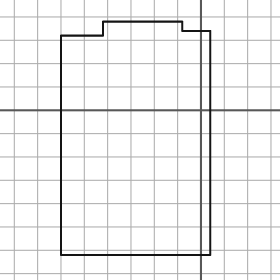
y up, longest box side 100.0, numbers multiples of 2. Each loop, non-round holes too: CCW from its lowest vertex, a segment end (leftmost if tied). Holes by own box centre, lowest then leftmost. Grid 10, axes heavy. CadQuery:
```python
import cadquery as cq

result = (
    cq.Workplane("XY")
    .moveTo(-60.0, -62.0)
    .lineTo(4.0, -62.0)
    .lineTo(4.0, 34.0)
    .lineTo(-8.0, 34.0)
    .lineTo(-8.0, 38.0)
    .lineTo(-42.0, 38.0)
    .lineTo(-42.0, 32.0)
    .lineTo(-60.0, 32.0)
    .close()
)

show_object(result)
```